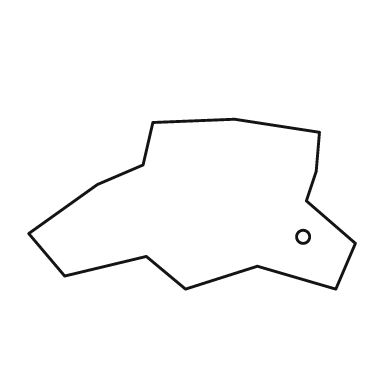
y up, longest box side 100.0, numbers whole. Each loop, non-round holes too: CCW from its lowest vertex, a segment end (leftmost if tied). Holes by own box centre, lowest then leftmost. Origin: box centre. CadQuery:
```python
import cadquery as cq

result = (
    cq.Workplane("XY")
    .moveTo(-2.0, -26.0)
    .lineTo(20.0, -19.0)
    .lineTo(44.0, -26.0)
    .lineTo(50.0, -12.0)
    .lineTo(35.0, 1.0)
    .lineTo(38.0, 10.0)
    .lineTo(39.0, 22.0)
    .lineTo(13.0, 26.0)
    .lineTo(-12.0, 25.0)
    .lineTo(-15.0, 12.0)
    .lineTo(-29.0, 6.0)
    .lineTo(-50.0, -9.0)
    .lineTo(-39.0, -22.0)
    .lineTo(-14.0, -16.0)
    .close()
    .moveTo(34.0, -10.0)
    .circle(2.0)
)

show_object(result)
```